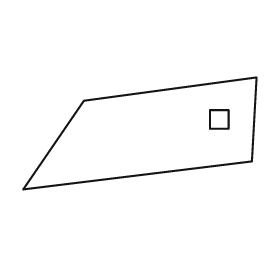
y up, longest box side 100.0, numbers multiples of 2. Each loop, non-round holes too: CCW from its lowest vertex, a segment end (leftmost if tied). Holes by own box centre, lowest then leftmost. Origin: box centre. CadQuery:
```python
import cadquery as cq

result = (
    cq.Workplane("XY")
    .moveTo(-50.0, -24.0)
    .lineTo(48.0, -12.0)
    .lineTo(50.0, 24.0)
    .lineTo(-24.0, 14.0)
    .close()
    .moveTo(30.0, 2.0)
    .lineTo(38.0, 2.0)
    .lineTo(38.0, 10.0)
    .lineTo(30.0, 10.0)
    .close()
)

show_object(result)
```